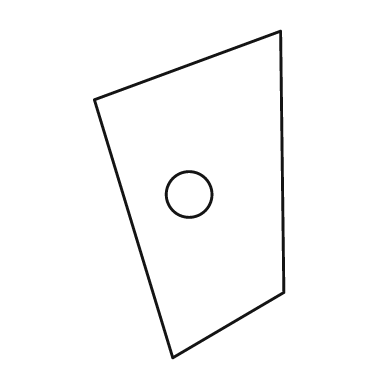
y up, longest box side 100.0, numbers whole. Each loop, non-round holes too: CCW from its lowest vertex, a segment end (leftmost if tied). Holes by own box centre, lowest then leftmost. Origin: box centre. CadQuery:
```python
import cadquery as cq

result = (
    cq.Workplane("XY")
    .moveTo(-5.0, -50.0)
    .lineTo(29.0, -30.0)
    .lineTo(28.0, 50.0)
    .lineTo(-29.0, 29.0)
    .close()
    .moveTo(0.0, 0.0)
    .circle(7.0)
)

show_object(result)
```